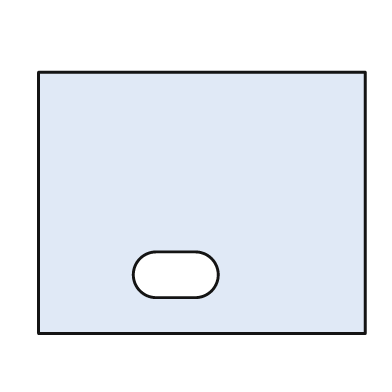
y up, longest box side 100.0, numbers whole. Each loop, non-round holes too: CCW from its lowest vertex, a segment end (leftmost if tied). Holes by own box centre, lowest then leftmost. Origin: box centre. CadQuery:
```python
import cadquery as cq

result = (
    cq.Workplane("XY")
    .moveTo(-50.0, -40.0)
    .lineTo(50.0, -40.0)
    .lineTo(50.0, 40.0)
    .lineTo(-50.0, 40.0)
    .close()
    .moveTo(-14.0, -29.0)
    .lineTo(-2.0, -29.0)
    .threePointArc((5.0, -22.0), (-2.0, -15.0))
    .lineTo(-14.0, -15.0)
    .threePointArc((-21.0, -22.0), (-14.0, -29.0))
    .close()
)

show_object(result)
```